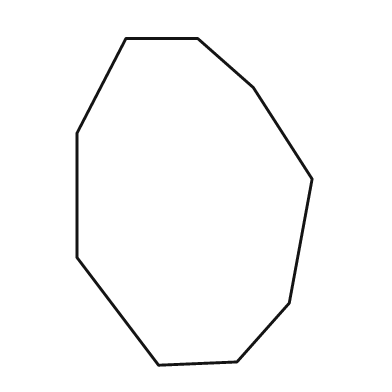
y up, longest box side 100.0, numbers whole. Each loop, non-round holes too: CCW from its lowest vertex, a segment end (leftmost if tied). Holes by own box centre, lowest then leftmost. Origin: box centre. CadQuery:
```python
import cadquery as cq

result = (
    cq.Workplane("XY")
    .moveTo(-11.0, -50.0)
    .lineTo(13.0, -49.0)
    .lineTo(29.0, -31.0)
    .lineTo(36.0, 7.0)
    .lineTo(18.0, 35.0)
    .lineTo(1.0, 50.0)
    .lineTo(-21.0, 50.0)
    .lineTo(-36.0, 21.0)
    .lineTo(-36.0, -17.0)
    .close()
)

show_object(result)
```